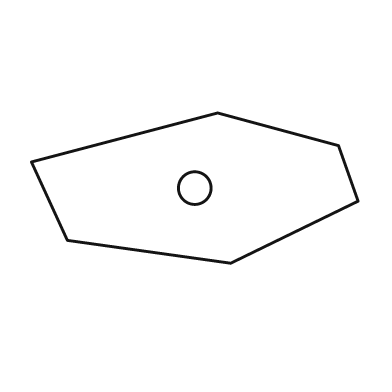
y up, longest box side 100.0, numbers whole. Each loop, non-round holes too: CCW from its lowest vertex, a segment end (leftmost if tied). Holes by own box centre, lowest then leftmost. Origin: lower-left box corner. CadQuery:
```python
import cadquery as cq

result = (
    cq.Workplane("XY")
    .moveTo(61.0, 0.0)
    .lineTo(100.0, 19.0)
    .lineTo(94.0, 36.0)
    .lineTo(57.0, 46.0)
    .lineTo(0.0, 31.0)
    .lineTo(11.0, 7.0)
    .close()
    .moveTo(50.0, 23.0)
    .circle(5.0)
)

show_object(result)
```